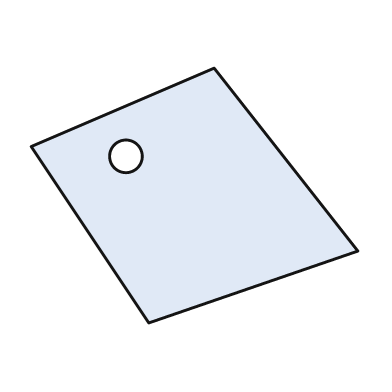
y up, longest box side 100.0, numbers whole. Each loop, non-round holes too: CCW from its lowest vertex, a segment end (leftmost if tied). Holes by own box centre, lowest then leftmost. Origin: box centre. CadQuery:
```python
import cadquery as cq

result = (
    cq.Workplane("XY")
    .moveTo(-14.0, -39.0)
    .lineTo(50.0, -17.0)
    .lineTo(6.0, 39.0)
    .lineTo(-50.0, 15.0)
    .close()
    .moveTo(-21.0, 12.0)
    .circle(5.0)
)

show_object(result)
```